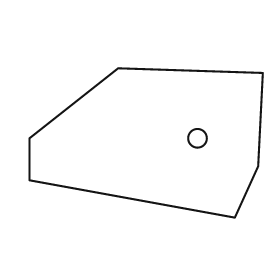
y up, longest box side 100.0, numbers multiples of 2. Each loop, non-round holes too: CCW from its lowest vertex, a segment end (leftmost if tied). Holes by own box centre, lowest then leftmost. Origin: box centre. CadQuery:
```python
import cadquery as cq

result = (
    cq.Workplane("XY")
    .moveTo(38.0, -32.0)
    .lineTo(48.0, -10.0)
    .lineTo(50.0, 30.0)
    .lineTo(-12.0, 32.0)
    .lineTo(-50.0, 2.0)
    .lineTo(-50.0, -16.0)
    .close()
    .moveTo(22.0, 2.0)
    .circle(4.0)
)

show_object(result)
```